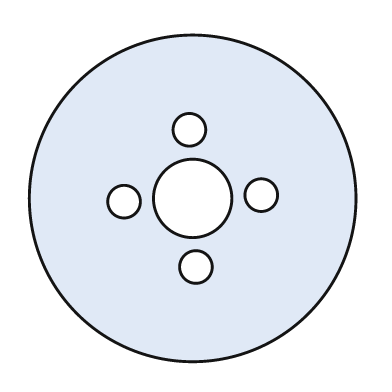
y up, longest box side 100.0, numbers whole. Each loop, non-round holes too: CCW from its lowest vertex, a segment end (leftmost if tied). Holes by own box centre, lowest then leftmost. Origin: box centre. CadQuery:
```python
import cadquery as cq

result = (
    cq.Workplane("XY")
    .moveTo(0.0, 0.0)
    .circle(50.0)
    .moveTo(1.0, -21.0)
    .circle(5.0)
    .moveTo(-21.0, -1.0)
    .circle(5.0)
    .moveTo(0.0, 0.0)
    .circle(12.0)
    .moveTo(21.0, 1.0)
    .circle(5.0)
    .moveTo(-1.0, 21.0)
    .circle(5.0)
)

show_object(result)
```